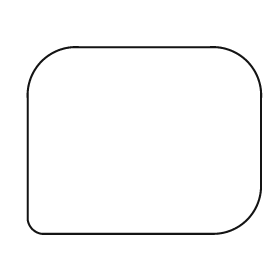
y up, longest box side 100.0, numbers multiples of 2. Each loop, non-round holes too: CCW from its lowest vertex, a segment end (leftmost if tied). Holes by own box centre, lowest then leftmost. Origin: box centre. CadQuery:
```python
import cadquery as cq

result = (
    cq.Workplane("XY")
    .moveTo(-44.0, -40.0)
    .lineTo(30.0, -40.0)
    .threePointArc((44.0, -34.0), (50.0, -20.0))
    .lineTo(50.0, 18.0)
    .threePointArc((44.0, 34.0), (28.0, 40.0))
    .lineTo(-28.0, 40.0)
    .threePointArc((-44.0, 34.0), (-50.0, 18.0))
    .lineTo(-50.0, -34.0)
    .threePointArc((-48.0, -38.0), (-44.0, -40.0))
    .close()
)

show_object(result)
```